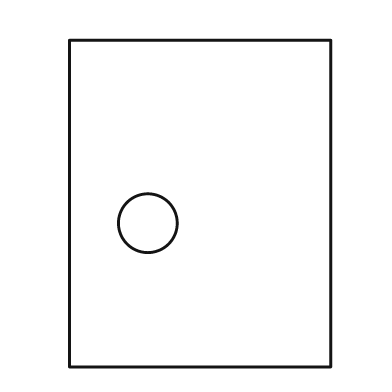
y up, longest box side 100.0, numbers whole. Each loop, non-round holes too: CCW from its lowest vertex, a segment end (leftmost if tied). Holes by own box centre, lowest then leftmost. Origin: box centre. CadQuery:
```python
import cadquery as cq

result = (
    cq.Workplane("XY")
    .moveTo(-40.0, -50.0)
    .lineTo(40.0, -50.0)
    .lineTo(40.0, 50.0)
    .lineTo(-40.0, 50.0)
    .close()
    .moveTo(-16.0, -6.0)
    .circle(9.0)
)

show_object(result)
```